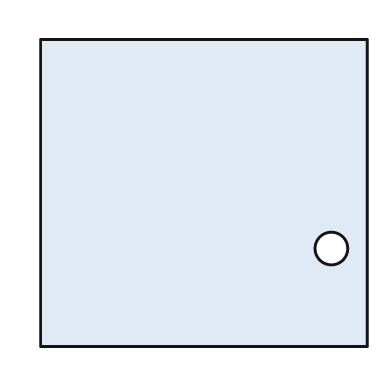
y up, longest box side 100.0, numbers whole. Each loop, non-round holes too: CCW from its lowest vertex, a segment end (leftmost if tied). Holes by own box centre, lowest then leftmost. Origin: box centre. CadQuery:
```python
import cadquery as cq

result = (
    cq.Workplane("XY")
    .moveTo(-50.0, -47.0)
    .lineTo(50.0, -47.0)
    .lineTo(50.0, 47.0)
    .lineTo(-50.0, 47.0)
    .close()
    .moveTo(39.0, -17.0)
    .circle(5.0)
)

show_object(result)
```